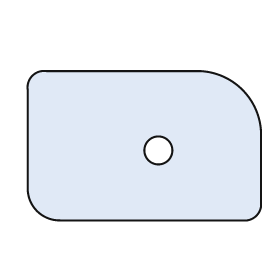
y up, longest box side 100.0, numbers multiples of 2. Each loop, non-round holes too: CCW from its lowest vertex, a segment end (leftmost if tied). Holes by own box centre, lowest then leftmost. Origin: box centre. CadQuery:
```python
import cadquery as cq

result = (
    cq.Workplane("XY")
    .moveTo(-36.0, -32.0)
    .lineTo(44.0, -32.0)
    .threePointArc((48.0, -30.0), (50.0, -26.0))
    .lineTo(50.0, 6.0)
    .threePointArc((42.0, 24.0), (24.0, 32.0))
    .lineTo(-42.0, 32.0)
    .threePointArc((-48.0, 30.0), (-50.0, 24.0))
    .lineTo(-50.0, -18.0)
    .threePointArc((-46.0, -28.0), (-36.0, -32.0))
    .close()
    .moveTo(6.0, -2.0)
    .circle(6.0)
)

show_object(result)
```